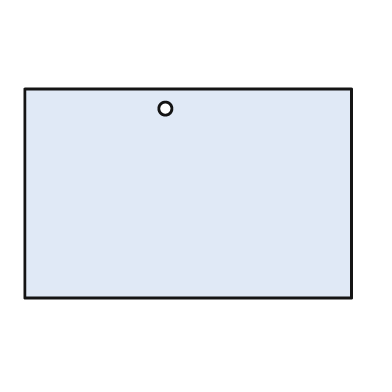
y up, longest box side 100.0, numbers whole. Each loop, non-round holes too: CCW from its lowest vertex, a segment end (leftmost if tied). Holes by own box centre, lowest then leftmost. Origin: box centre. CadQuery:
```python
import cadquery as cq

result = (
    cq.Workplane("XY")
    .moveTo(-50.0, -32.0)
    .lineTo(50.0, -32.0)
    .lineTo(50.0, 32.0)
    .lineTo(-50.0, 32.0)
    .close()
    .moveTo(-7.0, 26.0)
    .circle(2.0)
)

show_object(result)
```